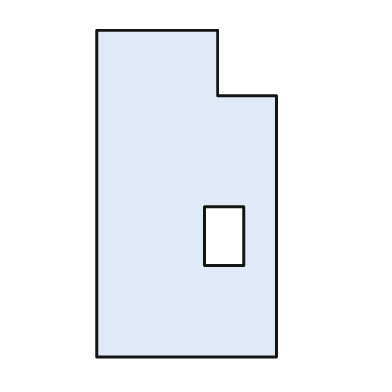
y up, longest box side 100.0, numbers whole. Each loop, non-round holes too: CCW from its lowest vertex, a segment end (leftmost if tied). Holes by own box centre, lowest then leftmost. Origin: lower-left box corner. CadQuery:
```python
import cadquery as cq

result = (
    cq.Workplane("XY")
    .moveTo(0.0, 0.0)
    .lineTo(55.0, 0.0)
    .lineTo(55.0, 80.0)
    .lineTo(37.0, 80.0)
    .lineTo(37.0, 100.0)
    .lineTo(0.0, 100.0)
    .close()
    .moveTo(33.0, 28.0)
    .lineTo(45.0, 28.0)
    .lineTo(45.0, 46.0)
    .lineTo(33.0, 46.0)
    .close()
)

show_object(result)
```